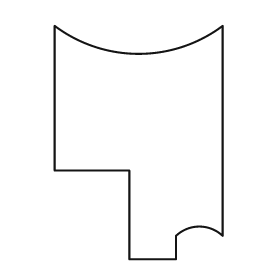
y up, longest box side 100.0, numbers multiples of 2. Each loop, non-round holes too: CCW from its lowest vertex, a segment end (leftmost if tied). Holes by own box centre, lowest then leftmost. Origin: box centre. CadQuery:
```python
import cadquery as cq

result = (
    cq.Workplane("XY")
    .moveTo(-4.0, -50.0)
    .lineTo(16.0, -50.0)
    .lineTo(16.0, -40.0)
    .threePointArc((26.0, -36.0), (36.0, -40.0))
    .lineTo(36.0, 50.0)
    .threePointArc((0.0, 38.0), (-36.0, 50.0))
    .lineTo(-36.0, -12.0)
    .lineTo(-4.0, -12.0)
    .close()
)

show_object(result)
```